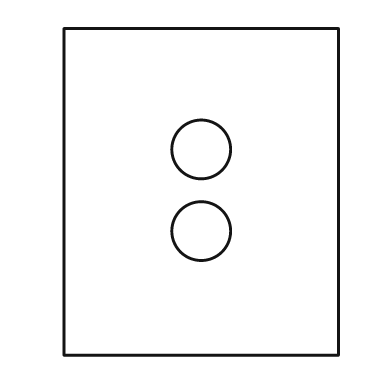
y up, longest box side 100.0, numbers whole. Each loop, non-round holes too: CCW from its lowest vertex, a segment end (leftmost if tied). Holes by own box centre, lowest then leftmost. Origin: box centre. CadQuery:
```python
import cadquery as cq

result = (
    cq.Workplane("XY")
    .moveTo(-42.0, -50.0)
    .lineTo(42.0, -50.0)
    .lineTo(42.0, 50.0)
    .lineTo(-42.0, 50.0)
    .close()
    .moveTo(0.0, -12.0)
    .circle(9.0)
    .moveTo(0.0, 13.0)
    .circle(9.0)
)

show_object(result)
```